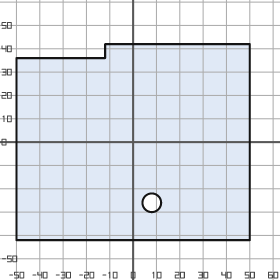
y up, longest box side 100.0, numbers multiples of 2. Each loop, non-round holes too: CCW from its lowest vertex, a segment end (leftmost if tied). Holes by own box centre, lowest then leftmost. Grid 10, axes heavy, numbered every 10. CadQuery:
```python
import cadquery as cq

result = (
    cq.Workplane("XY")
    .moveTo(-50.0, -42.0)
    .lineTo(50.0, -42.0)
    .lineTo(50.0, 42.0)
    .lineTo(-12.0, 42.0)
    .lineTo(-12.0, 36.0)
    .lineTo(-50.0, 36.0)
    .close()
    .moveTo(8.0, -26.0)
    .circle(4.0)
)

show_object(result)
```